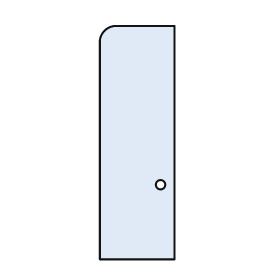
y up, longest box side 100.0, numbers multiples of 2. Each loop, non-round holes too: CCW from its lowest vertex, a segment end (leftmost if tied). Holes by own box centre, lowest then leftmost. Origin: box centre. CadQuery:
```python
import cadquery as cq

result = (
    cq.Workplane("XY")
    .moveTo(-16.0, -50.0)
    .lineTo(16.0, -50.0)
    .lineTo(16.0, 50.0)
    .lineTo(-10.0, 50.0)
    .threePointArc((-14.0, 48.0), (-16.0, 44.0))
    .close()
    .moveTo(10.0, -18.0)
    .circle(2.0)
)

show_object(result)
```